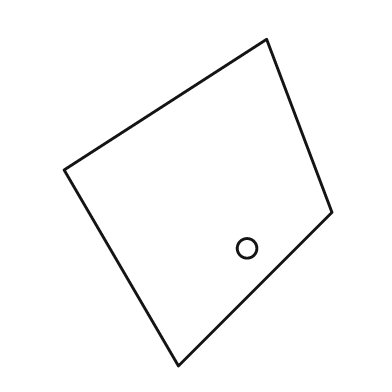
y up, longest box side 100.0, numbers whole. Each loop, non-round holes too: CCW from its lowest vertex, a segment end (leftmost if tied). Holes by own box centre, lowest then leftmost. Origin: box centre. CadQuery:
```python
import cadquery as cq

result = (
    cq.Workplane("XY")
    .moveTo(-6.0, -50.0)
    .lineTo(41.0, -3.0)
    .lineTo(21.0, 50.0)
    .lineTo(-41.0, 10.0)
    .close()
    .moveTo(15.0, -14.0)
    .circle(3.0)
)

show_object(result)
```